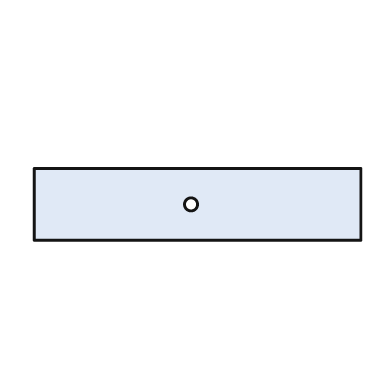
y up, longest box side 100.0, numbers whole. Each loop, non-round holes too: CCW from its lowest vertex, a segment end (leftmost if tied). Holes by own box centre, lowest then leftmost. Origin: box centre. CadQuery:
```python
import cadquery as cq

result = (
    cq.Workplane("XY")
    .moveTo(-50.0, -11.0)
    .lineTo(50.0, -11.0)
    .lineTo(50.0, 11.0)
    .lineTo(-50.0, 11.0)
    .close()
    .moveTo(-2.0, 0.0)
    .circle(2.0)
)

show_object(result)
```